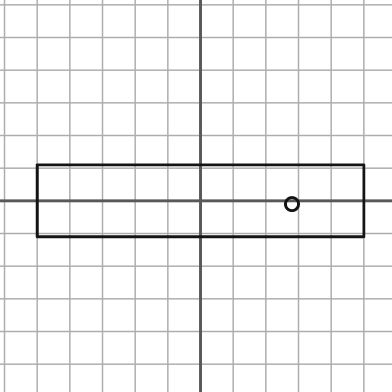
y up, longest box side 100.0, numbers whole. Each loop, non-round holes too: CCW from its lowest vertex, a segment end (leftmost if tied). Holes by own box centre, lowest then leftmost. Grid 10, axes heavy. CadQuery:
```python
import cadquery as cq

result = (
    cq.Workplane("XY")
    .moveTo(-50.0, -11.0)
    .lineTo(50.0, -11.0)
    .lineTo(50.0, 11.0)
    .lineTo(-50.0, 11.0)
    .close()
    .moveTo(28.0, -1.0)
    .circle(2.0)
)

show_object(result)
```